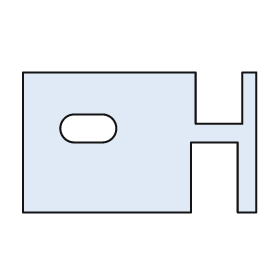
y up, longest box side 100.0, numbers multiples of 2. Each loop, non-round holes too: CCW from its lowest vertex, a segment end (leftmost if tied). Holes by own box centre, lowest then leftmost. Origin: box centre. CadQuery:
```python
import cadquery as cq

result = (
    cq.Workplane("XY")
    .moveTo(-50.0, -30.0)
    .lineTo(22.0, -30.0)
    .lineTo(22.0, 0.0)
    .lineTo(42.0, 0.0)
    .lineTo(42.0, -30.0)
    .lineTo(50.0, -30.0)
    .lineTo(50.0, 30.0)
    .lineTo(44.0, 30.0)
    .lineTo(44.0, 8.0)
    .lineTo(24.0, 8.0)
    .lineTo(24.0, 30.0)
    .lineTo(-50.0, 30.0)
    .close()
    .moveTo(-28.0, 0.0)
    .lineTo(-16.0, 0.0)
    .threePointArc((-10.0, 6.0), (-16.0, 12.0))
    .lineTo(-28.0, 12.0)
    .threePointArc((-34.0, 6.0), (-28.0, 0.0))
    .close()
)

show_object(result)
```